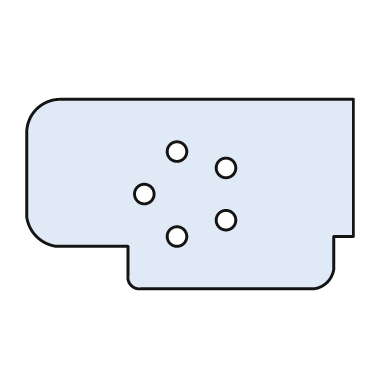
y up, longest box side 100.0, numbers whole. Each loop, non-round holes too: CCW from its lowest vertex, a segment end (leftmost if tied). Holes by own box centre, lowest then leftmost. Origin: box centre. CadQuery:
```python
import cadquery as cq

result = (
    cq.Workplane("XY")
    .moveTo(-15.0, -29.0)
    .lineTo(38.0, -29.0)
    .threePointArc((42.0, -27.0), (44.0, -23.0))
    .lineTo(44.0, -13.0)
    .lineTo(50.0, -13.0)
    .lineTo(50.0, 29.0)
    .lineTo(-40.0, 29.0)
    .threePointArc((-47.0, 26.0), (-50.0, 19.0))
    .lineTo(-50.0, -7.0)
    .threePointArc((-47.0, -13.0), (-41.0, -16.0))
    .lineTo(-19.0, -16.0)
    .lineTo(-19.0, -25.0)
    .threePointArc((-18.0, -28.0), (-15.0, -29.0))
    .close()
    .moveTo(-4.0, -13.0)
    .circle(3.0)
    .moveTo(11.0, -8.0)
    .circle(3.0)
    .moveTo(-14.0, 0.0)
    .circle(3.0)
    .moveTo(11.0, 8.0)
    .circle(3.0)
    .moveTo(-4.0, 13.0)
    .circle(3.0)
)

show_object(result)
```